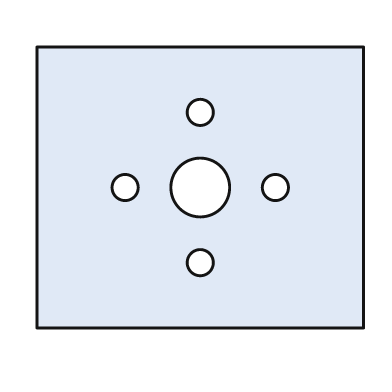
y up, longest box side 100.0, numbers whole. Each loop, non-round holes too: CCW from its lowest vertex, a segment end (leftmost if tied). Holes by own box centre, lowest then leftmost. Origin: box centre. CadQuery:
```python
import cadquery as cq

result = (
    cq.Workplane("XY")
    .moveTo(-50.0, -43.0)
    .lineTo(50.0, -43.0)
    .lineTo(50.0, 43.0)
    .lineTo(-50.0, 43.0)
    .close()
    .moveTo(0.0, -23.0)
    .circle(4.0)
    .moveTo(-23.0, 0.0)
    .circle(4.0)
    .moveTo(0.0, 0.0)
    .circle(9.0)
    .moveTo(23.0, 0.0)
    .circle(4.0)
    .moveTo(0.0, 23.0)
    .circle(4.0)
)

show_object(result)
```